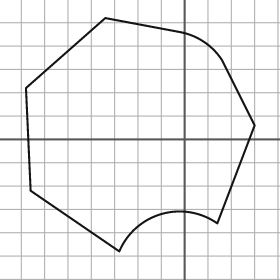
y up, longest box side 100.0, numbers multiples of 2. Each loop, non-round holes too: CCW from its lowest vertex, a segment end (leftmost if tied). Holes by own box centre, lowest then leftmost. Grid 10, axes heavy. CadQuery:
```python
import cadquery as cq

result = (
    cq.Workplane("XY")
    .moveTo(-28.0, -48.0)
    .threePointArc((-10.0, -32.0), (14.0, -36.0))
    .lineTo(30.0, 6.0)
    .lineTo(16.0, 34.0)
    .threePointArc((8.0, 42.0), (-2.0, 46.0))
    .lineTo(-34.0, 52.0)
    .lineTo(-68.0, 22.0)
    .lineTo(-66.0, -22.0)
    .close()
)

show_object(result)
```